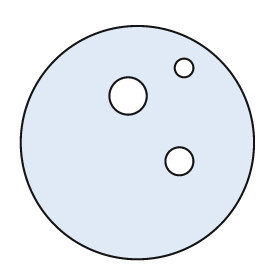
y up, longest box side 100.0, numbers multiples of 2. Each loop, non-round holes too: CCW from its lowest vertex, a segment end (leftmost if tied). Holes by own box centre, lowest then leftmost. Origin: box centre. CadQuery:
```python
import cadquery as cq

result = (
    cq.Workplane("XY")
    .moveTo(0.0, 0.0)
    .circle(50.0)
    .moveTo(18.0, -8.0)
    .circle(6.0)
    .moveTo(-4.0, 20.0)
    .circle(8.0)
    .moveTo(20.0, 32.0)
    .circle(4.0)
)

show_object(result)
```